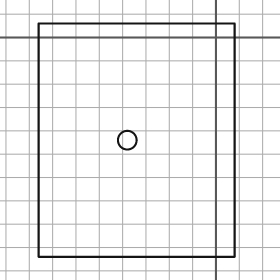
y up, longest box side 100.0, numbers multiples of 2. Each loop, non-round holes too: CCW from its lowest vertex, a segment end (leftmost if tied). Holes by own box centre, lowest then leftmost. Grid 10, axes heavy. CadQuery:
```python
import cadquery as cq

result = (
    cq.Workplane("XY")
    .moveTo(-76.0, -94.0)
    .lineTo(8.0, -94.0)
    .lineTo(8.0, 6.0)
    .lineTo(-76.0, 6.0)
    .close()
    .moveTo(-38.0, -44.0)
    .circle(4.0)
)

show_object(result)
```